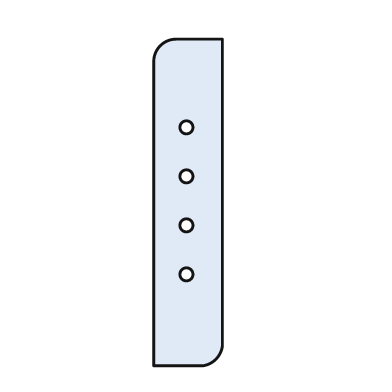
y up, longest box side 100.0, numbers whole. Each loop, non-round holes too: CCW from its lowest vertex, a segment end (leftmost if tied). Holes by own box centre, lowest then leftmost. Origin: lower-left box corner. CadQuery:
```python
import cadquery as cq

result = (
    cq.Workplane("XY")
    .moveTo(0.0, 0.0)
    .lineTo(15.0, 0.0)
    .threePointArc((19.0, 2.0), (21.0, 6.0))
    .lineTo(21.0, 100.0)
    .lineTo(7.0, 100.0)
    .threePointArc((2.0, 98.0), (0.0, 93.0))
    .close()
    .moveTo(10.0, 28.0)
    .circle(2.0)
    .moveTo(10.0, 43.0)
    .circle(2.0)
    .moveTo(10.0, 58.0)
    .circle(2.0)
    .moveTo(10.0, 73.0)
    .circle(2.0)
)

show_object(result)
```